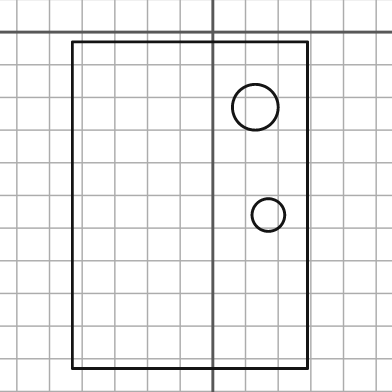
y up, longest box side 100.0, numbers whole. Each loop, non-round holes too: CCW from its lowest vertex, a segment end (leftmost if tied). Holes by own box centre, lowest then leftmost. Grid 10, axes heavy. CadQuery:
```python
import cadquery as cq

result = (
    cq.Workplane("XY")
    .moveTo(-43.0, -103.0)
    .lineTo(29.0, -103.0)
    .lineTo(29.0, -3.0)
    .lineTo(-43.0, -3.0)
    .close()
    .moveTo(17.0, -56.0)
    .circle(5.0)
    .moveTo(13.0, -23.0)
    .circle(7.0)
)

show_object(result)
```